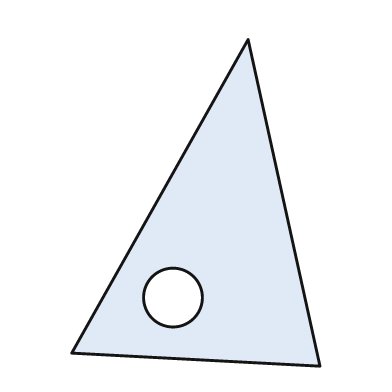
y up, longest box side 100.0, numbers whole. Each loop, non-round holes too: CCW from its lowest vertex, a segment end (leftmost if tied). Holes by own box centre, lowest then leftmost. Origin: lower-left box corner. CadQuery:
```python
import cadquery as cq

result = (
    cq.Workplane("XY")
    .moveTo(76.0, 0.0)
    .lineTo(54.0, 100.0)
    .lineTo(0.0, 4.0)
    .close()
    .moveTo(31.0, 21.0)
    .circle(9.0)
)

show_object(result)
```